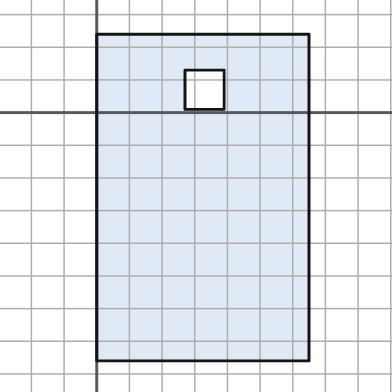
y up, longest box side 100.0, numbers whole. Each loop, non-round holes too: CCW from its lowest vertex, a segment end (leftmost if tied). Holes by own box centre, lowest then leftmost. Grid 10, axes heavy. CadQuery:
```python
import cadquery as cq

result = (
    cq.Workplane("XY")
    .moveTo(0.0, -76.0)
    .lineTo(65.0, -76.0)
    .lineTo(65.0, 24.0)
    .lineTo(0.0, 24.0)
    .close()
    .moveTo(27.0, 1.0)
    .lineTo(39.0, 1.0)
    .lineTo(39.0, 13.0)
    .lineTo(27.0, 13.0)
    .close()
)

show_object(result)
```